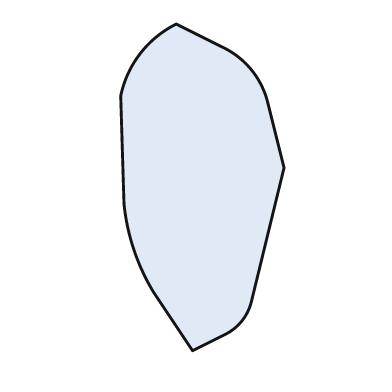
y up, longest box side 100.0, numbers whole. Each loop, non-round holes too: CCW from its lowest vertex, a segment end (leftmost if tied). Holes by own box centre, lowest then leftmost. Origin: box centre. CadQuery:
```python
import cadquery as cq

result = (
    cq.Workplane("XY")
    .moveTo(-3.0, -50.0)
    .lineTo(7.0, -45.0)
    .threePointArc((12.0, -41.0), (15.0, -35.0))
    .lineTo(25.0, 6.0)
    .lineTo(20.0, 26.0)
    .threePointArc((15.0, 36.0), (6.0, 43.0))
    .lineTo(-8.0, 50.0)
    .threePointArc((-19.0, 41.0), (-25.0, 28.0))
    .lineTo(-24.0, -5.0)
    .threePointArc((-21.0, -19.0), (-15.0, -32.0))
    .close()
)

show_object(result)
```